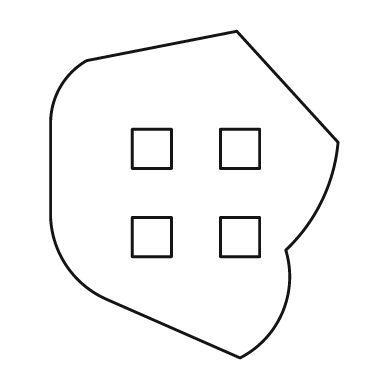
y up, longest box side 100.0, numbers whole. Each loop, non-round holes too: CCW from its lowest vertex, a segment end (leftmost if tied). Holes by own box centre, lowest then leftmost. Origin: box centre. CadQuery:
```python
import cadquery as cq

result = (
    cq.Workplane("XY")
    .moveTo(14.0, -50.0)
    .threePointArc((27.0, -36.0), (28.0, -17.0))
    .threePointArc((39.0, -2.0), (44.0, 16.0))
    .lineTo(13.0, 50.0)
    .lineTo(-33.0, 41.0)
    .threePointArc((-41.0, 33.0), (-44.0, 22.0))
    .lineTo(-44.0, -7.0)
    .threePointArc((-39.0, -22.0), (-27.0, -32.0))
    .close()
    .moveTo(-19.0, -19.0)
    .lineTo(-7.0, -19.0)
    .lineTo(-7.0, -7.0)
    .lineTo(-19.0, -7.0)
    .close()
    .moveTo(8.0, -19.0)
    .lineTo(20.0, -19.0)
    .lineTo(20.0, -7.0)
    .lineTo(8.0, -7.0)
    .close()
    .moveTo(-19.0, 8.0)
    .lineTo(-7.0, 8.0)
    .lineTo(-7.0, 20.0)
    .lineTo(-19.0, 20.0)
    .close()
    .moveTo(8.0, 8.0)
    .lineTo(20.0, 8.0)
    .lineTo(20.0, 20.0)
    .lineTo(8.0, 20.0)
    .close()
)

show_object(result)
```